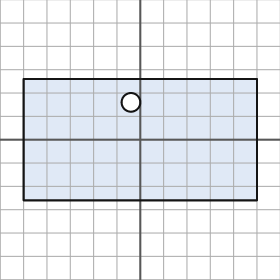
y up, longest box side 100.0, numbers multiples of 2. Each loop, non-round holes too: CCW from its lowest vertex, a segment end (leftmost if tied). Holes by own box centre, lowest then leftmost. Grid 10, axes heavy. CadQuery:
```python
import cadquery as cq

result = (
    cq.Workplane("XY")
    .moveTo(-50.0, -26.0)
    .lineTo(50.0, -26.0)
    .lineTo(50.0, 26.0)
    .lineTo(-50.0, 26.0)
    .close()
    .moveTo(-4.0, 16.0)
    .circle(4.0)
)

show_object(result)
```